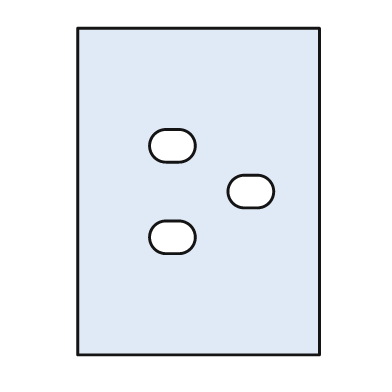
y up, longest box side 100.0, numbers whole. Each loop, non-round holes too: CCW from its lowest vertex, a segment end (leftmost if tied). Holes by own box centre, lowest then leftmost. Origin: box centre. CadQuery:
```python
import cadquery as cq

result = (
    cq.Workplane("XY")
    .moveTo(-37.0, -50.0)
    .lineTo(37.0, -50.0)
    .lineTo(37.0, 50.0)
    .lineTo(-37.0, 50.0)
    .close()
    .moveTo(-10.0, -19.0)
    .lineTo(-6.0, -19.0)
    .threePointArc((-1.0, -14.0), (-6.0, -9.0))
    .lineTo(-10.0, -9.0)
    .threePointArc((-15.0, -14.0), (-10.0, -19.0))
    .close()
    .moveTo(14.0, -5.0)
    .lineTo(18.0, -5.0)
    .threePointArc((23.0, 0.0), (18.0, 5.0))
    .lineTo(14.0, 5.0)
    .threePointArc((9.0, 0.0), (14.0, -5.0))
    .close()
    .moveTo(-10.0, 9.0)
    .lineTo(-6.0, 9.0)
    .threePointArc((-1.0, 14.0), (-6.0, 19.0))
    .lineTo(-10.0, 19.0)
    .threePointArc((-15.0, 14.0), (-10.0, 9.0))
    .close()
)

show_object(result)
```